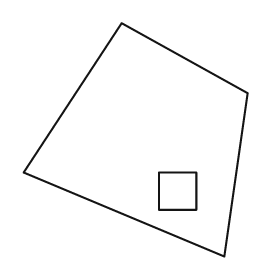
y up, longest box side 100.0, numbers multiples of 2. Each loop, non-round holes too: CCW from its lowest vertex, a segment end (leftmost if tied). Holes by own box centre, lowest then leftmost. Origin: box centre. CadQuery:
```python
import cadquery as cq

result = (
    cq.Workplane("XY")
    .moveTo(38.0, -50.0)
    .lineTo(48.0, 20.0)
    .lineTo(-6.0, 50.0)
    .lineTo(-48.0, -14.0)
    .close()
    .moveTo(10.0, -30.0)
    .lineTo(26.0, -30.0)
    .lineTo(26.0, -14.0)
    .lineTo(10.0, -14.0)
    .close()
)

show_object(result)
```